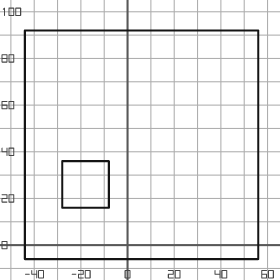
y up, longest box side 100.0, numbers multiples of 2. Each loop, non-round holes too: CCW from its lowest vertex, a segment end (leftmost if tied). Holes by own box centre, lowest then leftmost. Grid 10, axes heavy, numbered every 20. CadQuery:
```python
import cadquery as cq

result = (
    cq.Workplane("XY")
    .moveTo(-44.0, -6.0)
    .lineTo(56.0, -6.0)
    .lineTo(56.0, 92.0)
    .lineTo(-44.0, 92.0)
    .close()
    .moveTo(-28.0, 16.0)
    .lineTo(-8.0, 16.0)
    .lineTo(-8.0, 36.0)
    .lineTo(-28.0, 36.0)
    .close()
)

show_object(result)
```